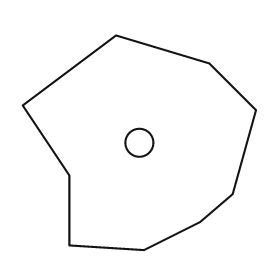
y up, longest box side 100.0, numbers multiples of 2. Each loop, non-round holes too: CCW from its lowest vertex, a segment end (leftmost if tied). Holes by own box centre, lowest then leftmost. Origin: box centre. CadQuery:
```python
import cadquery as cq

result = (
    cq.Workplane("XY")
    .moveTo(2.0, -46.0)
    .lineTo(26.0, -34.0)
    .lineTo(40.0, -22.0)
    .lineTo(50.0, 14.0)
    .lineTo(30.0, 34.0)
    .lineTo(-10.0, 46.0)
    .lineTo(-50.0, 16.0)
    .lineTo(-30.0, -14.0)
    .lineTo(-30.0, -44.0)
    .close()
    .moveTo(0.0, 0.0)
    .circle(6.0)
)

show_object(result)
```